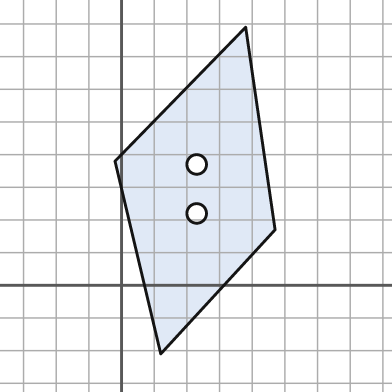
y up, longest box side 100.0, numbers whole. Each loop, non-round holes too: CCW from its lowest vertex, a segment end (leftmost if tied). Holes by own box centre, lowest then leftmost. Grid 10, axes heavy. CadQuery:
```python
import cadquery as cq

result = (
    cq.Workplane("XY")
    .moveTo(12.0, -21.0)
    .lineTo(47.0, 17.0)
    .lineTo(38.0, 79.0)
    .lineTo(-2.0, 38.0)
    .close()
    .moveTo(23.0, 22.0)
    .circle(3.0)
    .moveTo(23.0, 37.0)
    .circle(3.0)
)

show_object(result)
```